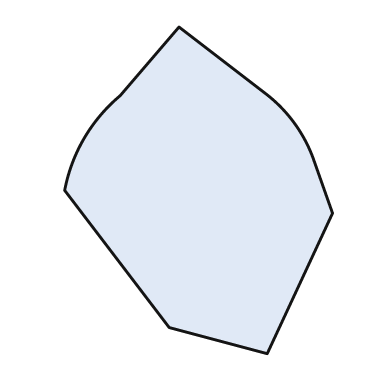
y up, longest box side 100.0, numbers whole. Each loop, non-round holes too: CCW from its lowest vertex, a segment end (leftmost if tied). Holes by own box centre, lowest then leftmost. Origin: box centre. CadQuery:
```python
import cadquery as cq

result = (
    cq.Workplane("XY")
    .moveTo(21.0, -50.0)
    .lineTo(41.0, -7.0)
    .lineTo(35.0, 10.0)
    .threePointArc((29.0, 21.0), (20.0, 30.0))
    .lineTo(-6.0, 50.0)
    .lineTo(-24.0, 29.0)
    .threePointArc((-35.0, 16.0), (-41.0, 0.0))
    .lineTo(-9.0, -42.0)
    .close()
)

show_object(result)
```